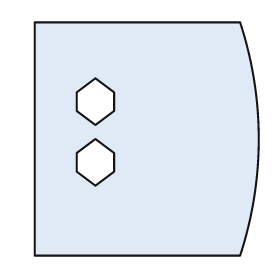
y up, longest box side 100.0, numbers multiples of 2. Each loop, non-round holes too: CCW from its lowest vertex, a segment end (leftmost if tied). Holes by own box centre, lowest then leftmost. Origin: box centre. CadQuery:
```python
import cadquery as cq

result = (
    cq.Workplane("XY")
    .moveTo(-48.0, -50.0)
    .lineTo(40.0, -50.0)
    .threePointArc((48.0, 0.0), (40.0, 50.0))
    .lineTo(-48.0, 50.0)
    .close()
    .moveTo(-22.0, -20.0)
    .lineTo(-14.0, -14.0)
    .lineTo(-14.0, -6.0)
    .lineTo(-22.0, 0.0)
    .lineTo(-30.0, -6.0)
    .lineTo(-30.0, -14.0)
    .close()
    .moveTo(-22.0, 6.0)
    .lineTo(-14.0, 12.0)
    .lineTo(-14.0, 20.0)
    .lineTo(-22.0, 26.0)
    .lineTo(-30.0, 20.0)
    .lineTo(-30.0, 12.0)
    .close()
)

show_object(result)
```